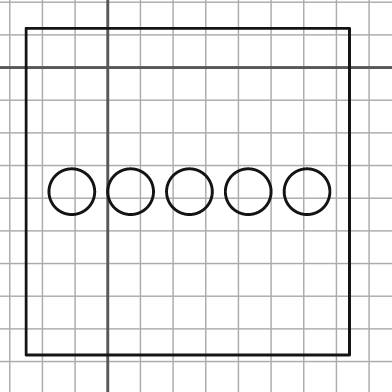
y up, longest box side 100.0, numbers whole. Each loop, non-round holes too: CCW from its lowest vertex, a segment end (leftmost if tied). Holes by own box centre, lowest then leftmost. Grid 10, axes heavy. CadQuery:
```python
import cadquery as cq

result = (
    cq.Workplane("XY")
    .moveTo(-25.0, -88.0)
    .lineTo(74.0, -88.0)
    .lineTo(74.0, 12.0)
    .lineTo(-25.0, 12.0)
    .close()
    .moveTo(-11.0, -38.0)
    .circle(7.0)
    .moveTo(7.0, -38.0)
    .circle(7.0)
    .moveTo(25.0, -38.0)
    .circle(7.0)
    .moveTo(43.0, -38.0)
    .circle(7.0)
    .moveTo(61.0, -38.0)
    .circle(7.0)
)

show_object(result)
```